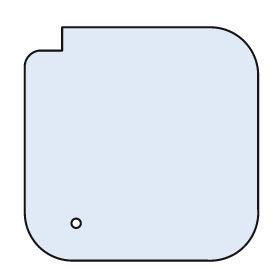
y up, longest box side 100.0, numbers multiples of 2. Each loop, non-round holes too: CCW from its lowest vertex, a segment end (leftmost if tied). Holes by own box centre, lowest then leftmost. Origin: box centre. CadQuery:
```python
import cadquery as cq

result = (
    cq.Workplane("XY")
    .moveTo(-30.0, -50.0)
    .lineTo(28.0, -50.0)
    .threePointArc((44.0, -44.0), (50.0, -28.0))
    .lineTo(50.0, 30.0)
    .threePointArc((44.0, 44.0), (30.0, 50.0))
    .lineTo(-34.0, 50.0)
    .lineTo(-34.0, 40.0)
    .lineTo(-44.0, 40.0)
    .threePointArc((-48.0, 38.0), (-50.0, 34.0))
    .lineTo(-50.0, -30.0)
    .threePointArc((-44.0, -44.0), (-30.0, -50.0))
    .close()
    .moveTo(-28.0, -34.0)
    .circle(2.0)
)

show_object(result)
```